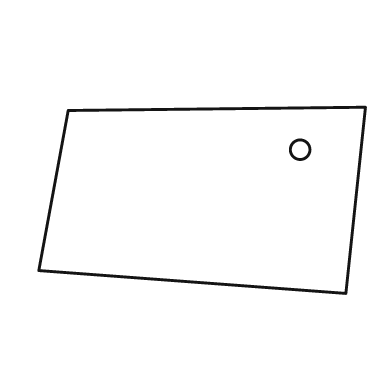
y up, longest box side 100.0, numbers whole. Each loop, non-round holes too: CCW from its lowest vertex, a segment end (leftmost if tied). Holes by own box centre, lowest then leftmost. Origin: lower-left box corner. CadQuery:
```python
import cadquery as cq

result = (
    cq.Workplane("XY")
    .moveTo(94.0, 0.0)
    .lineTo(100.0, 57.0)
    .lineTo(9.0, 56.0)
    .lineTo(0.0, 7.0)
    .close()
    .moveTo(80.0, 44.0)
    .circle(3.0)
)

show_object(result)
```